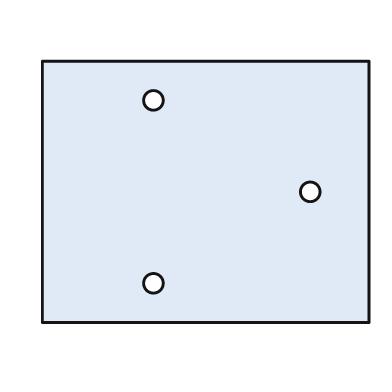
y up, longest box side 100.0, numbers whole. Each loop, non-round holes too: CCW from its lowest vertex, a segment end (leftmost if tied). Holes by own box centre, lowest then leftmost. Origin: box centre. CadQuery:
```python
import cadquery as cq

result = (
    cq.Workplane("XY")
    .moveTo(-50.0, -40.0)
    .lineTo(50.0, -40.0)
    .lineTo(50.0, 40.0)
    .lineTo(-50.0, 40.0)
    .close()
    .moveTo(-16.0, -28.0)
    .circle(3.0)
    .moveTo(32.0, 0.0)
    .circle(3.0)
    .moveTo(-16.0, 28.0)
    .circle(3.0)
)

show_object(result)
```